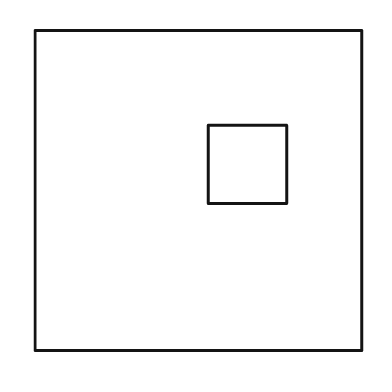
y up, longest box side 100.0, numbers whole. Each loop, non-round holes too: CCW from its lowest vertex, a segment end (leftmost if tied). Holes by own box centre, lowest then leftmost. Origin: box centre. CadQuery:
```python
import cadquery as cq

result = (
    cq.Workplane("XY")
    .moveTo(-50.0, -49.0)
    .lineTo(50.0, -49.0)
    .lineTo(50.0, 49.0)
    .lineTo(-50.0, 49.0)
    .close()
    .moveTo(3.0, -4.0)
    .lineTo(27.0, -4.0)
    .lineTo(27.0, 20.0)
    .lineTo(3.0, 20.0)
    .close()
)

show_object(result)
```